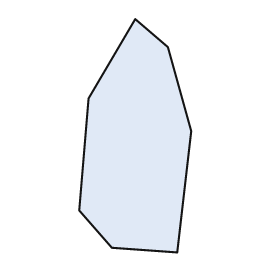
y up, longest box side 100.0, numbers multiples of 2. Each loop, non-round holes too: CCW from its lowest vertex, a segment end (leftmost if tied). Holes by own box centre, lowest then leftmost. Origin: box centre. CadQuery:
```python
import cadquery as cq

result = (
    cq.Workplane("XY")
    .moveTo(18.0, -50.0)
    .lineTo(24.0, 2.0)
    .lineTo(14.0, 38.0)
    .lineTo(0.0, 50.0)
    .lineTo(-20.0, 16.0)
    .lineTo(-24.0, -32.0)
    .lineTo(-10.0, -48.0)
    .close()
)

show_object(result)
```